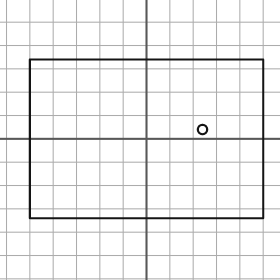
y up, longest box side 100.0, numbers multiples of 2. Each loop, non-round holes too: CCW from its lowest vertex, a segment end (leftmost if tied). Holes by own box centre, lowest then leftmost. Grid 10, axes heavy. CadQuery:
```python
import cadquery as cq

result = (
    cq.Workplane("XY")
    .moveTo(-50.0, -34.0)
    .lineTo(50.0, -34.0)
    .lineTo(50.0, 34.0)
    .lineTo(-50.0, 34.0)
    .close()
    .moveTo(24.0, 4.0)
    .circle(2.0)
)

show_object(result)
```